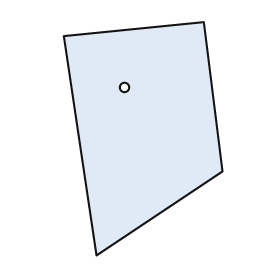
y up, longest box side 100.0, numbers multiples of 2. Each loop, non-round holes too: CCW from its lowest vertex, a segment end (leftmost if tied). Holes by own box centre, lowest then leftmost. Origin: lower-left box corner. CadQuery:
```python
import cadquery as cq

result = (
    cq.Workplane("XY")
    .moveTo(14.0, 0.0)
    .lineTo(68.0, 36.0)
    .lineTo(60.0, 100.0)
    .lineTo(0.0, 94.0)
    .close()
    .moveTo(26.0, 72.0)
    .circle(2.0)
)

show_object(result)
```